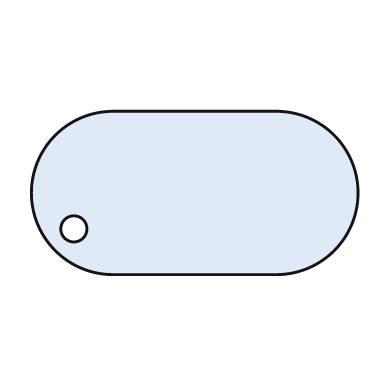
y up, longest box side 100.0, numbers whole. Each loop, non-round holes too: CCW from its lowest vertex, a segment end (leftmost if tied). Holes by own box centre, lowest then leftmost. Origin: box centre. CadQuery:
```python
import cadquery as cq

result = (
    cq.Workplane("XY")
    .moveTo(-25.0, -25.0)
    .lineTo(25.0, -25.0)
    .threePointArc((50.0, 0.0), (25.0, 25.0))
    .lineTo(-25.0, 25.0)
    .threePointArc((-50.0, 0.0), (-25.0, -25.0))
    .close()
    .moveTo(-37.0, -11.0)
    .circle(4.0)
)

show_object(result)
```